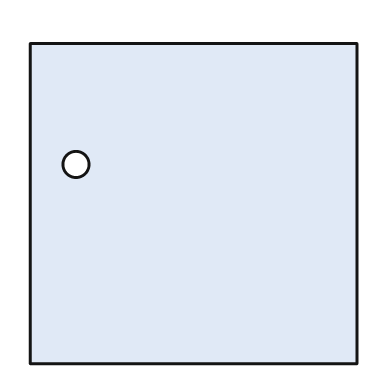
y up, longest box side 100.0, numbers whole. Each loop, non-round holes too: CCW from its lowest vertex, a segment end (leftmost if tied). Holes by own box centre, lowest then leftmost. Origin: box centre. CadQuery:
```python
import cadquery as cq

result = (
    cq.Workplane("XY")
    .moveTo(-50.0, -49.0)
    .lineTo(50.0, -49.0)
    .lineTo(50.0, 49.0)
    .lineTo(-50.0, 49.0)
    .close()
    .moveTo(-36.0, 12.0)
    .circle(4.0)
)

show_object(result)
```